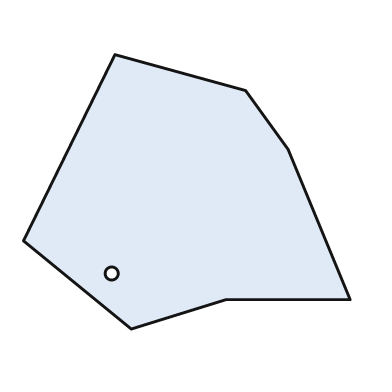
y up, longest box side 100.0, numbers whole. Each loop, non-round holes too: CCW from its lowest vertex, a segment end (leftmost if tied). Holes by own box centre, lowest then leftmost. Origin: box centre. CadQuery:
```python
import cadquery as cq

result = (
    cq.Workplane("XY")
    .moveTo(-17.0, -42.0)
    .lineTo(12.0, -33.0)
    .lineTo(50.0, -33.0)
    .lineTo(31.0, 13.0)
    .lineTo(18.0, 31.0)
    .lineTo(-22.0, 42.0)
    .lineTo(-50.0, -15.0)
    .close()
    .moveTo(-23.0, -25.0)
    .circle(2.0)
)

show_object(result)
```